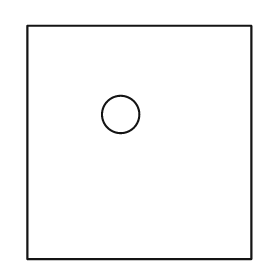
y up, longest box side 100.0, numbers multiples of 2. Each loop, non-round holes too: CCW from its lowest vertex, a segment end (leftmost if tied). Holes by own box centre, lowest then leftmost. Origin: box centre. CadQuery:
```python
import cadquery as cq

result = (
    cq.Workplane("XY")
    .moveTo(-48.0, -50.0)
    .lineTo(48.0, -50.0)
    .lineTo(48.0, 50.0)
    .lineTo(-48.0, 50.0)
    .close()
    .moveTo(-8.0, 12.0)
    .circle(8.0)
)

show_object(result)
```